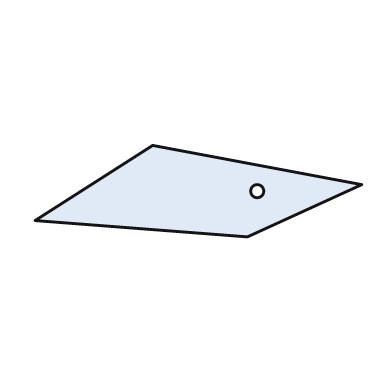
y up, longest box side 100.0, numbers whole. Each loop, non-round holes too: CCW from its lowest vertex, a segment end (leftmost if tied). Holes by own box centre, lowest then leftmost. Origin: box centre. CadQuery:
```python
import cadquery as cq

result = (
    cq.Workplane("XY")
    .moveTo(15.0, -14.0)
    .lineTo(50.0, 2.0)
    .lineTo(-14.0, 14.0)
    .lineTo(-50.0, -9.0)
    .close()
    .moveTo(18.0, 0.0)
    .circle(2.0)
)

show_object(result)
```